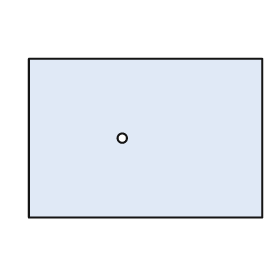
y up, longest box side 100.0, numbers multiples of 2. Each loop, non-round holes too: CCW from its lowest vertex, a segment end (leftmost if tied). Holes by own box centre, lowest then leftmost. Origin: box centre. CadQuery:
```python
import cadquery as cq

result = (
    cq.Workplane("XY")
    .moveTo(-50.0, -34.0)
    .lineTo(50.0, -34.0)
    .lineTo(50.0, 34.0)
    .lineTo(-50.0, 34.0)
    .close()
    .moveTo(-10.0, 0.0)
    .circle(2.0)
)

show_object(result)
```